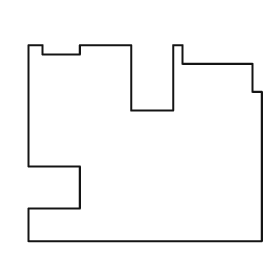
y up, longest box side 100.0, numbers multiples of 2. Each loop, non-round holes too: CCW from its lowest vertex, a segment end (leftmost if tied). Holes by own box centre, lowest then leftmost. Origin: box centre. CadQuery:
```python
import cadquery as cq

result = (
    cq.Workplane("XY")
    .moveTo(-50.0, -42.0)
    .lineTo(50.0, -42.0)
    .lineTo(50.0, 22.0)
    .lineTo(46.0, 22.0)
    .lineTo(46.0, 34.0)
    .lineTo(16.0, 34.0)
    .lineTo(16.0, 42.0)
    .lineTo(12.0, 42.0)
    .lineTo(12.0, 14.0)
    .lineTo(-6.0, 14.0)
    .lineTo(-6.0, 42.0)
    .lineTo(-28.0, 42.0)
    .lineTo(-28.0, 38.0)
    .lineTo(-44.0, 38.0)
    .lineTo(-44.0, 42.0)
    .lineTo(-50.0, 42.0)
    .lineTo(-50.0, -10.0)
    .lineTo(-28.0, -10.0)
    .lineTo(-28.0, -28.0)
    .lineTo(-50.0, -28.0)
    .close()
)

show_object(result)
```